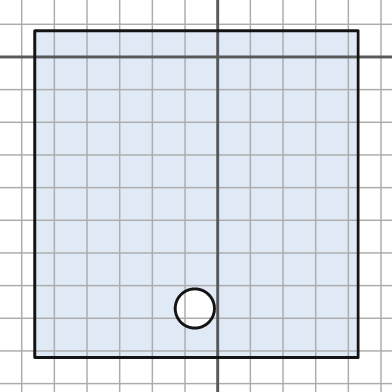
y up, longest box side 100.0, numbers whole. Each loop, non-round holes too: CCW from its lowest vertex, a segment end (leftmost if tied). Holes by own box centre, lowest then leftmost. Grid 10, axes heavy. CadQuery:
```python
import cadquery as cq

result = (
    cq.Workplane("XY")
    .moveTo(-56.0, -92.0)
    .lineTo(43.0, -92.0)
    .lineTo(43.0, 8.0)
    .lineTo(-56.0, 8.0)
    .close()
    .moveTo(-7.0, -77.0)
    .circle(6.0)
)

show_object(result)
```